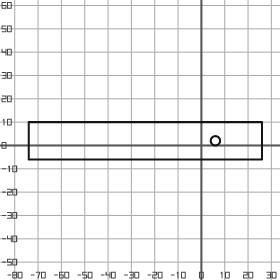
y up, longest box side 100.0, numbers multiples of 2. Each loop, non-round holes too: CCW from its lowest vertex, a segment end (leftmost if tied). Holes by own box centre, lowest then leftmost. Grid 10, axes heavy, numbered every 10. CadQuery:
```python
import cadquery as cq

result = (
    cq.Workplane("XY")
    .moveTo(-74.0, -6.0)
    .lineTo(26.0, -6.0)
    .lineTo(26.0, 10.0)
    .lineTo(-74.0, 10.0)
    .close()
    .moveTo(6.0, 2.0)
    .circle(2.0)
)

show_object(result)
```